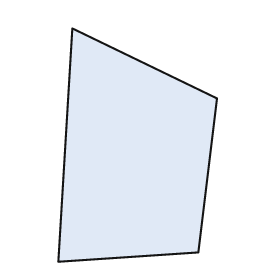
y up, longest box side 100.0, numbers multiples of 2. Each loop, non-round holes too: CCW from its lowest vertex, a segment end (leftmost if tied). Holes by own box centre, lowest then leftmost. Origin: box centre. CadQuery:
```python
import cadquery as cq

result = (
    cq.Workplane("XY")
    .moveTo(-34.0, -50.0)
    .lineTo(26.0, -46.0)
    .lineTo(34.0, 20.0)
    .lineTo(-28.0, 50.0)
    .close()
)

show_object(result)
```